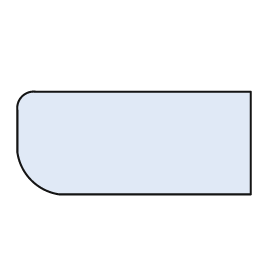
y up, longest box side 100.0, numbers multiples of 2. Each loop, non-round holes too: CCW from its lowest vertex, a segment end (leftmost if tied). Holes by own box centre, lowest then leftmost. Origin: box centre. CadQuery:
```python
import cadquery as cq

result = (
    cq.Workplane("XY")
    .moveTo(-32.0, -22.0)
    .lineTo(50.0, -22.0)
    .lineTo(50.0, 22.0)
    .lineTo(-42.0, 22.0)
    .threePointArc((-48.0, 20.0), (-50.0, 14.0))
    .lineTo(-50.0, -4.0)
    .threePointArc((-44.0, -16.0), (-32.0, -22.0))
    .close()
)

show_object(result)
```